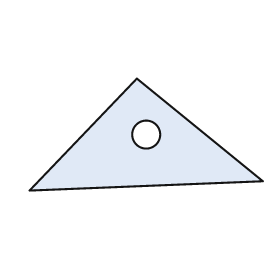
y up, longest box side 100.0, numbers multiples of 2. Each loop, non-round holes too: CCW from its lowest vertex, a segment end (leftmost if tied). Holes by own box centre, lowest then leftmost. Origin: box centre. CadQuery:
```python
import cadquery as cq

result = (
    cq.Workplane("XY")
    .moveTo(-50.0, -24.0)
    .lineTo(50.0, -20.0)
    .lineTo(-4.0, 24.0)
    .close()
    .moveTo(0.0, 0.0)
    .circle(6.0)
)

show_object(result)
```